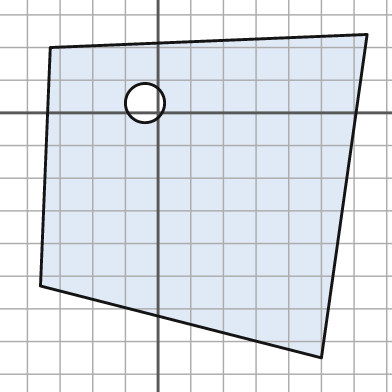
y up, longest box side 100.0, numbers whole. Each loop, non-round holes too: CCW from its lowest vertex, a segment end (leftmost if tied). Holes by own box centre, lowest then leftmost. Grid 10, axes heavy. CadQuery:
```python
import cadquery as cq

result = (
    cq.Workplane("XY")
    .moveTo(50.0, -75.0)
    .lineTo(64.0, 24.0)
    .lineTo(-33.0, 20.0)
    .lineTo(-36.0, -53.0)
    .close()
    .moveTo(-4.0, 3.0)
    .circle(6.0)
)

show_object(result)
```